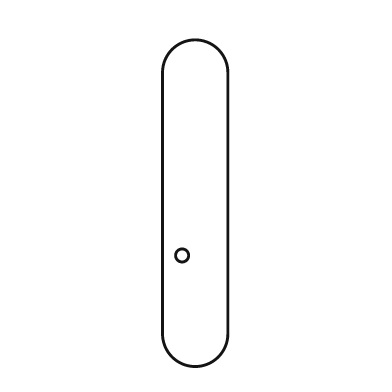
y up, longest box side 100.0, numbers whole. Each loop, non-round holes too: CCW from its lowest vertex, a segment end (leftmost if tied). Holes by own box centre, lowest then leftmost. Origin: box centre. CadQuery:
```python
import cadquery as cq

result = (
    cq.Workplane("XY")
    .moveTo(-10.0, -40.0)
    .threePointArc((0.0, -50.0), (10.0, -40.0))
    .lineTo(10.0, 40.0)
    .threePointArc((0.0, 50.0), (-10.0, 40.0))
    .close()
    .moveTo(-4.0, -16.0)
    .circle(2.0)
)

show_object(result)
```